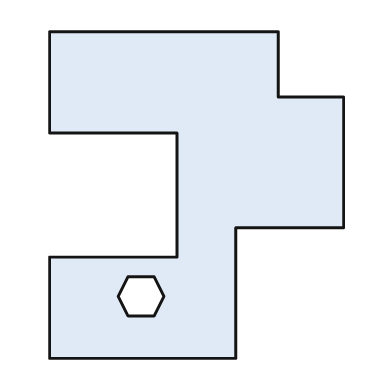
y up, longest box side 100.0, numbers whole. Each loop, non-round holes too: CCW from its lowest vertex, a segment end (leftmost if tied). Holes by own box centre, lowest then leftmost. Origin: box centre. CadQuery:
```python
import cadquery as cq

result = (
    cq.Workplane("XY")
    .moveTo(-45.0, -50.0)
    .lineTo(12.0, -50.0)
    .lineTo(12.0, -10.0)
    .lineTo(45.0, -10.0)
    .lineTo(45.0, 30.0)
    .lineTo(25.0, 30.0)
    .lineTo(25.0, 50.0)
    .lineTo(-45.0, 50.0)
    .lineTo(-45.0, 19.0)
    .lineTo(-6.0, 19.0)
    .lineTo(-6.0, -19.0)
    .lineTo(-45.0, -19.0)
    .close()
    .moveTo(-21.0, -37.0)
    .lineTo(-13.0, -37.0)
    .lineTo(-10.0, -31.0)
    .lineTo(-13.0, -25.0)
    .lineTo(-21.0, -25.0)
    .lineTo(-24.0, -31.0)
    .close()
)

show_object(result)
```